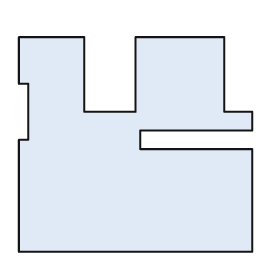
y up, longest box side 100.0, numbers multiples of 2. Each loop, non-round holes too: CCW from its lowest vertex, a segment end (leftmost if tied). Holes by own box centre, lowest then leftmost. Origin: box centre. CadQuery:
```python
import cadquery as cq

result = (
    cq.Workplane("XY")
    .moveTo(-50.0, -46.0)
    .lineTo(50.0, -46.0)
    .lineTo(50.0, -2.0)
    .lineTo(2.0, -2.0)
    .lineTo(2.0, 6.0)
    .lineTo(50.0, 6.0)
    .lineTo(50.0, 14.0)
    .lineTo(38.0, 14.0)
    .lineTo(38.0, 46.0)
    .lineTo(0.0, 46.0)
    .lineTo(0.0, 14.0)
    .lineTo(-22.0, 14.0)
    .lineTo(-22.0, 46.0)
    .lineTo(-50.0, 46.0)
    .lineTo(-50.0, 26.0)
    .lineTo(-46.0, 26.0)
    .lineTo(-46.0, 2.0)
    .lineTo(-50.0, 2.0)
    .close()
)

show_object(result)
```